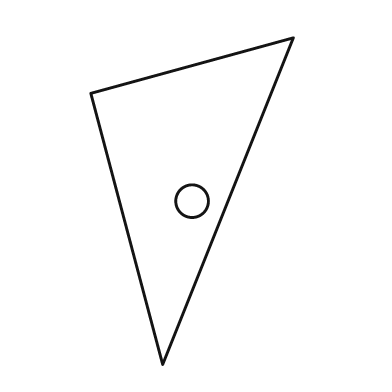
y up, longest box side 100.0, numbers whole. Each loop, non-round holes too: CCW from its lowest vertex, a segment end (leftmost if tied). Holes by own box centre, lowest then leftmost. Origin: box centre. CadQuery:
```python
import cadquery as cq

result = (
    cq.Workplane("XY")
    .moveTo(-9.0, -50.0)
    .lineTo(31.0, 50.0)
    .lineTo(-31.0, 33.0)
    .close()
    .moveTo(0.0, 0.0)
    .circle(5.0)
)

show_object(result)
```